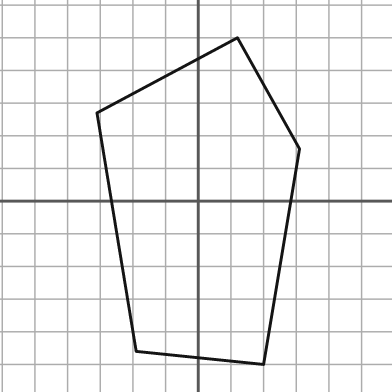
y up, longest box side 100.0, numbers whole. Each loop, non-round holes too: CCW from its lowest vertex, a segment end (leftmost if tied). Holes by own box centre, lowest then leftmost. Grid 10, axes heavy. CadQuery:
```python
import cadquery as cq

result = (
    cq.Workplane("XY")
    .moveTo(20.0, -50.0)
    .lineTo(31.0, 16.0)
    .lineTo(12.0, 50.0)
    .lineTo(-31.0, 27.0)
    .lineTo(-19.0, -46.0)
    .close()
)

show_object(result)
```